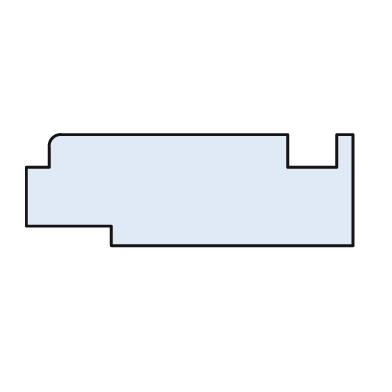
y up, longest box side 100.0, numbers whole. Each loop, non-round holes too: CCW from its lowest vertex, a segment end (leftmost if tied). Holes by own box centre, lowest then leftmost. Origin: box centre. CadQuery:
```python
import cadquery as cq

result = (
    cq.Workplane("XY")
    .moveTo(-24.0, -17.0)
    .lineTo(50.0, -17.0)
    .lineTo(50.0, 17.0)
    .lineTo(45.0, 17.0)
    .lineTo(45.0, 7.0)
    .lineTo(30.0, 7.0)
    .lineTo(30.0, 17.0)
    .lineTo(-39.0, 17.0)
    .threePointArc((-42.0, 16.0), (-43.0, 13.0))
    .lineTo(-43.0, 7.0)
    .lineTo(-50.0, 7.0)
    .lineTo(-50.0, -11.0)
    .lineTo(-24.0, -11.0)
    .close()
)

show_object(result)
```